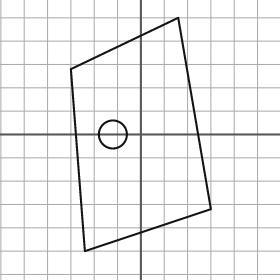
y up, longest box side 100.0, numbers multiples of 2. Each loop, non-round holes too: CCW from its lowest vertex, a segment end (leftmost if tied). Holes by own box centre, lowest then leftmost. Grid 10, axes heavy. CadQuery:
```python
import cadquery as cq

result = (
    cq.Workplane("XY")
    .moveTo(-24.0, -50.0)
    .lineTo(30.0, -32.0)
    .lineTo(16.0, 50.0)
    .lineTo(-30.0, 28.0)
    .close()
    .moveTo(-12.0, 0.0)
    .circle(6.0)
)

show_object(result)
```